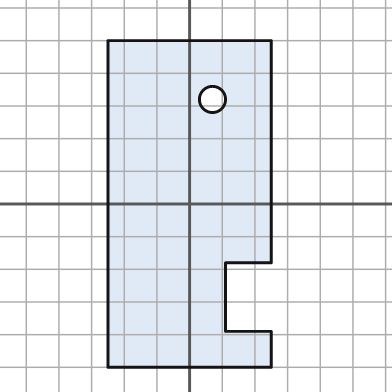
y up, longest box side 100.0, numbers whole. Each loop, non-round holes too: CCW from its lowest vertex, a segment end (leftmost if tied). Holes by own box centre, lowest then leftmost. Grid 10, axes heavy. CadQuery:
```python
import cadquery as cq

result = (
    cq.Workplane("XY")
    .moveTo(-25.0, -50.0)
    .lineTo(25.0, -50.0)
    .lineTo(25.0, -39.0)
    .lineTo(11.0, -39.0)
    .lineTo(11.0, -18.0)
    .lineTo(25.0, -18.0)
    .lineTo(25.0, 50.0)
    .lineTo(-25.0, 50.0)
    .close()
    .moveTo(7.0, 32.0)
    .circle(4.0)
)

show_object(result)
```